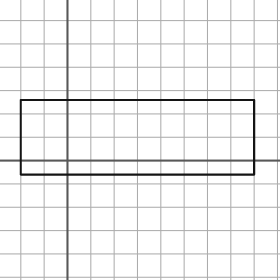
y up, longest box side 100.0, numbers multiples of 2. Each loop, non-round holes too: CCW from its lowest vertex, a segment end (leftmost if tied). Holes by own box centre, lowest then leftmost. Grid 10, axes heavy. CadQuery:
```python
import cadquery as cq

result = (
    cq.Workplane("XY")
    .moveTo(-20.0, -6.0)
    .lineTo(80.0, -6.0)
    .lineTo(80.0, 26.0)
    .lineTo(-20.0, 26.0)
    .close()
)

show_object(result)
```